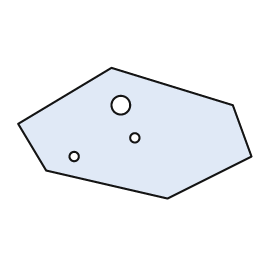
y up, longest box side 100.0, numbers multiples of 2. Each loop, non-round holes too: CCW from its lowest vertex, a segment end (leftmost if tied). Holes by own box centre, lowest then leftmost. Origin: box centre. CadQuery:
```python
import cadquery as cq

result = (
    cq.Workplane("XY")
    .moveTo(14.0, -28.0)
    .lineTo(50.0, -10.0)
    .lineTo(42.0, 12.0)
    .lineTo(-10.0, 28.0)
    .lineTo(-50.0, 4.0)
    .lineTo(-38.0, -16.0)
    .close()
    .moveTo(-26.0, -10.0)
    .circle(2.0)
    .moveTo(0.0, -2.0)
    .circle(2.0)
    .moveTo(-6.0, 12.0)
    .circle(4.0)
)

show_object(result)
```